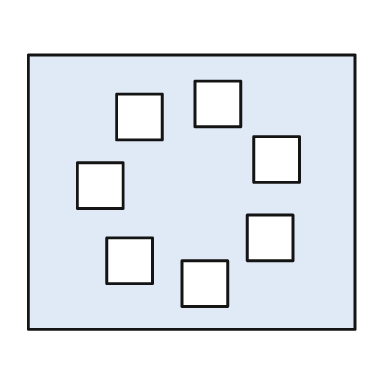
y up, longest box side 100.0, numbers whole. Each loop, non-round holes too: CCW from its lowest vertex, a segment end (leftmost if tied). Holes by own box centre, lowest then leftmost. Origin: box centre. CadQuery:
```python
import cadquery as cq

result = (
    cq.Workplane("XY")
    .moveTo(-50.0, -42.0)
    .lineTo(50.0, -42.0)
    .lineTo(50.0, 42.0)
    .lineTo(-50.0, 42.0)
    .close()
    .moveTo(-3.0, -35.0)
    .lineTo(11.0, -35.0)
    .lineTo(11.0, -21.0)
    .lineTo(-3.0, -21.0)
    .close()
    .moveTo(-26.0, -28.0)
    .lineTo(-12.0, -28.0)
    .lineTo(-12.0, -14.0)
    .lineTo(-26.0, -14.0)
    .close()
    .moveTo(17.0, -21.0)
    .lineTo(31.0, -21.0)
    .lineTo(31.0, -7.0)
    .lineTo(17.0, -7.0)
    .close()
    .moveTo(-35.0, -5.0)
    .lineTo(-21.0, -5.0)
    .lineTo(-21.0, 9.0)
    .lineTo(-35.0, 9.0)
    .close()
    .moveTo(19.0, 3.0)
    .lineTo(33.0, 3.0)
    .lineTo(33.0, 17.0)
    .lineTo(19.0, 17.0)
    .close()
    .moveTo(-23.0, 16.0)
    .lineTo(-9.0, 16.0)
    .lineTo(-9.0, 30.0)
    .lineTo(-23.0, 30.0)
    .close()
    .moveTo(1.0, 20.0)
    .lineTo(15.0, 20.0)
    .lineTo(15.0, 34.0)
    .lineTo(1.0, 34.0)
    .close()
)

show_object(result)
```